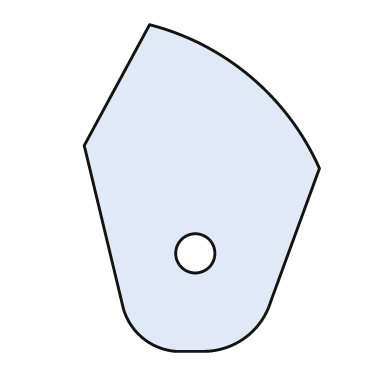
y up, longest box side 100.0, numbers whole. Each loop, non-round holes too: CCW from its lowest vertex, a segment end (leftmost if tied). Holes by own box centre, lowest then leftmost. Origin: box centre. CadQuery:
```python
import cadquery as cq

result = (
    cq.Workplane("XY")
    .moveTo(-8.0, -50.0)
    .lineTo(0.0, -50.0)
    .threePointArc((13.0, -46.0), (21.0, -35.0))
    .lineTo(36.0, 6.0)
    .threePointArc((15.0, 34.0), (-16.0, 50.0))
    .lineTo(-36.0, 13.0)
    .lineTo(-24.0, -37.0)
    .threePointArc((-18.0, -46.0), (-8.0, -50.0))
    .close()
    .moveTo(-2.0, -20.0)
    .circle(6.0)
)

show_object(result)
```